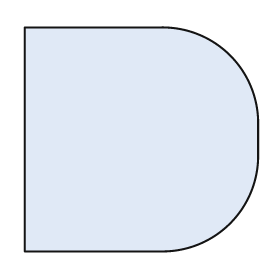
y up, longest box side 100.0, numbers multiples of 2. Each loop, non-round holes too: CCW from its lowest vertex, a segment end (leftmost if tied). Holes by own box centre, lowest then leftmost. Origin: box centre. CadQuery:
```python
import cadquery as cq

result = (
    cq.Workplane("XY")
    .moveTo(-50.0, -48.0)
    .lineTo(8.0, -48.0)
    .threePointArc((38.0, -36.0), (50.0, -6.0))
    .lineTo(50.0, 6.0)
    .threePointArc((38.0, 36.0), (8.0, 48.0))
    .lineTo(-50.0, 48.0)
    .close()
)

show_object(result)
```